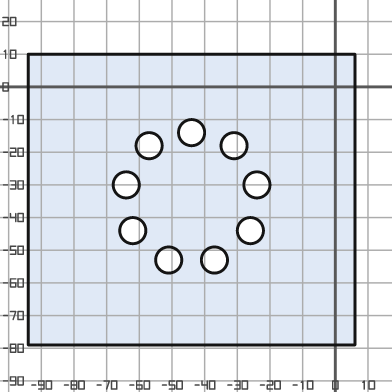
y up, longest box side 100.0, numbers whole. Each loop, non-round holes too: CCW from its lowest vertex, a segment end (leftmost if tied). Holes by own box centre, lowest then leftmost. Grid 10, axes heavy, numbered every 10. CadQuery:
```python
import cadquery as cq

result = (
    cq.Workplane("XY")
    .moveTo(-94.0, -79.0)
    .lineTo(6.0, -79.0)
    .lineTo(6.0, 10.0)
    .lineTo(-94.0, 10.0)
    .close()
    .moveTo(-51.0, -53.0)
    .circle(4.0)
    .moveTo(-37.0, -53.0)
    .circle(4.0)
    .moveTo(-62.0, -44.0)
    .circle(4.0)
    .moveTo(-26.0, -44.0)
    .circle(4.0)
    .moveTo(-64.0, -30.0)
    .circle(4.0)
    .moveTo(-24.0, -30.0)
    .circle(4.0)
    .moveTo(-57.0, -18.0)
    .circle(4.0)
    .moveTo(-31.0, -18.0)
    .circle(4.0)
    .moveTo(-44.0, -14.0)
    .circle(4.0)
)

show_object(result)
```